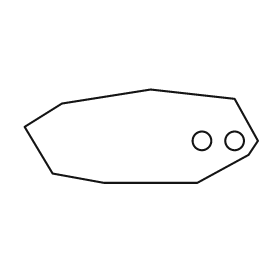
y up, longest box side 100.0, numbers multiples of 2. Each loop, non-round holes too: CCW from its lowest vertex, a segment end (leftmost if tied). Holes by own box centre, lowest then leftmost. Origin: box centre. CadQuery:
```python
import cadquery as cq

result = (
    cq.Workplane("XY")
    .moveTo(-16.0, -20.0)
    .lineTo(24.0, -20.0)
    .lineTo(46.0, -8.0)
    .lineTo(50.0, -2.0)
    .lineTo(40.0, 16.0)
    .lineTo(4.0, 20.0)
    .lineTo(-34.0, 14.0)
    .lineTo(-50.0, 4.0)
    .lineTo(-38.0, -16.0)
    .close()
    .moveTo(26.0, -2.0)
    .circle(4.0)
    .moveTo(40.0, -2.0)
    .circle(4.0)
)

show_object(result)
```